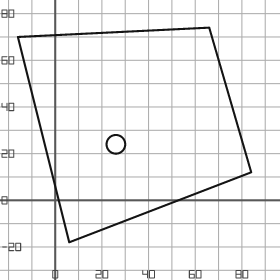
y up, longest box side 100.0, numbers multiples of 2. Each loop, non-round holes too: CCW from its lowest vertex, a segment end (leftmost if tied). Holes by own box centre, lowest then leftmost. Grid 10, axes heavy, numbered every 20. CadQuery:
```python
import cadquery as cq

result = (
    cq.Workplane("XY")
    .moveTo(6.0, -18.0)
    .lineTo(84.0, 12.0)
    .lineTo(66.0, 74.0)
    .lineTo(-16.0, 70.0)
    .close()
    .moveTo(26.0, 24.0)
    .circle(4.0)
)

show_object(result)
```